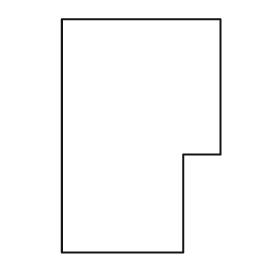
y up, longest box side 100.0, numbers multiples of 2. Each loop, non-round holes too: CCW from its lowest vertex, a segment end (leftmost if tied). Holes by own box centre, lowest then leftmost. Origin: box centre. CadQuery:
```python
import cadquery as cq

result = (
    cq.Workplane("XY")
    .moveTo(-34.0, -50.0)
    .lineTo(18.0, -50.0)
    .lineTo(18.0, -8.0)
    .lineTo(34.0, -8.0)
    .lineTo(34.0, 50.0)
    .lineTo(-34.0, 50.0)
    .close()
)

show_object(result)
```